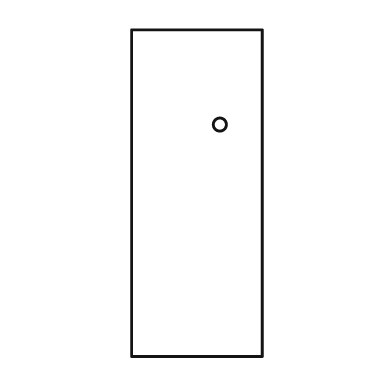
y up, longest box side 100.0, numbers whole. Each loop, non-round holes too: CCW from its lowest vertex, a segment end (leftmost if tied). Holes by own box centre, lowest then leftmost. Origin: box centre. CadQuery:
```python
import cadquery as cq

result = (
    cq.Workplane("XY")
    .moveTo(-20.0, -50.0)
    .lineTo(20.0, -50.0)
    .lineTo(20.0, 50.0)
    .lineTo(-20.0, 50.0)
    .close()
    .moveTo(7.0, 21.0)
    .circle(2.0)
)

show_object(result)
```